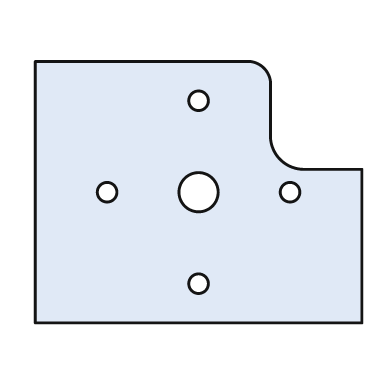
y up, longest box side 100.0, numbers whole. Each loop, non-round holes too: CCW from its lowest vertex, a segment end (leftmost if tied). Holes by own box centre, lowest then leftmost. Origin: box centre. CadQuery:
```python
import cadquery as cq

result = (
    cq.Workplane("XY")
    .moveTo(-50.0, -40.0)
    .lineTo(50.0, -40.0)
    .lineTo(50.0, 7.0)
    .lineTo(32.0, 7.0)
    .threePointArc((25.0, 10.0), (22.0, 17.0))
    .lineTo(22.0, 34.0)
    .threePointArc((20.0, 38.0), (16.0, 40.0))
    .lineTo(-50.0, 40.0)
    .close()
    .moveTo(0.0, -28.0)
    .circle(3.0)
    .moveTo(-28.0, 0.0)
    .circle(3.0)
    .moveTo(0.0, 0.0)
    .circle(6.0)
    .moveTo(28.0, 0.0)
    .circle(3.0)
    .moveTo(0.0, 28.0)
    .circle(3.0)
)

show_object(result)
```